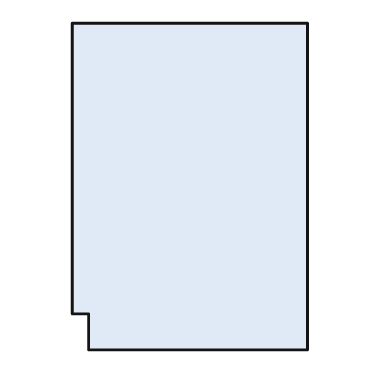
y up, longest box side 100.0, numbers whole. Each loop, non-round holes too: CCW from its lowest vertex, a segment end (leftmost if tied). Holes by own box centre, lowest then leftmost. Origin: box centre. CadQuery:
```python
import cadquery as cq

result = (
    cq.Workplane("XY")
    .moveTo(-31.0, -50.0)
    .lineTo(36.0, -50.0)
    .lineTo(36.0, 50.0)
    .lineTo(-36.0, 50.0)
    .lineTo(-36.0, -39.0)
    .lineTo(-31.0, -39.0)
    .close()
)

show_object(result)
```